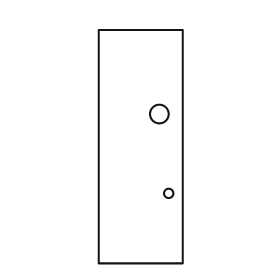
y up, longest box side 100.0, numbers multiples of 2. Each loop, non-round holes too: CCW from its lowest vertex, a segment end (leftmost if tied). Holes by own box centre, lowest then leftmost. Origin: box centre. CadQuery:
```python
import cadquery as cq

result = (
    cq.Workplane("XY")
    .moveTo(-18.0, -50.0)
    .lineTo(18.0, -50.0)
    .lineTo(18.0, 50.0)
    .lineTo(-18.0, 50.0)
    .close()
    .moveTo(12.0, -20.0)
    .circle(2.0)
    .moveTo(8.0, 14.0)
    .circle(4.0)
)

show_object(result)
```